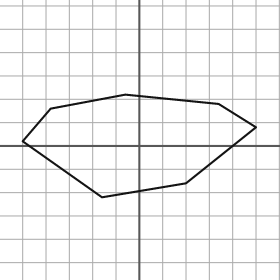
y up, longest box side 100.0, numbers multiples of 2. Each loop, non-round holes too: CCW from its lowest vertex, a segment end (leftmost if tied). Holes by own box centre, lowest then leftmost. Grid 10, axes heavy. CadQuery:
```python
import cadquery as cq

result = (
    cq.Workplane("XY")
    .moveTo(-16.0, -22.0)
    .lineTo(20.0, -16.0)
    .lineTo(50.0, 8.0)
    .lineTo(34.0, 18.0)
    .lineTo(-6.0, 22.0)
    .lineTo(-38.0, 16.0)
    .lineTo(-50.0, 2.0)
    .close()
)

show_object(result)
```